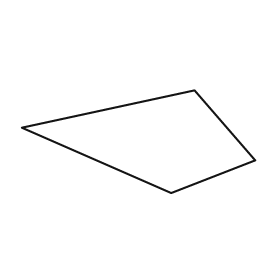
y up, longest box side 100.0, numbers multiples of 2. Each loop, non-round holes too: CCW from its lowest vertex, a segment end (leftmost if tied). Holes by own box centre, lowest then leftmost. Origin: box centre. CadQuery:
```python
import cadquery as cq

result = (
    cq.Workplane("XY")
    .moveTo(14.0, -22.0)
    .lineTo(50.0, -8.0)
    .lineTo(24.0, 22.0)
    .lineTo(-50.0, 6.0)
    .close()
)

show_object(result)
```